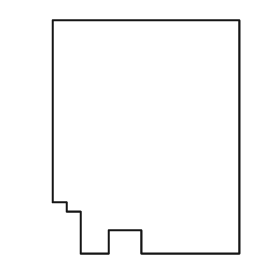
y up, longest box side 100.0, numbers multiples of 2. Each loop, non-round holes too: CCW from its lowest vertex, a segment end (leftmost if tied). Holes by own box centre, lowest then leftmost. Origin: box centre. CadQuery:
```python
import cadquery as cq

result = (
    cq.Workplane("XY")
    .moveTo(-28.0, -50.0)
    .lineTo(-16.0, -50.0)
    .lineTo(-16.0, -40.0)
    .lineTo(-2.0, -40.0)
    .lineTo(-2.0, -50.0)
    .lineTo(40.0, -50.0)
    .lineTo(40.0, 50.0)
    .lineTo(-40.0, 50.0)
    .lineTo(-40.0, -28.0)
    .lineTo(-34.0, -28.0)
    .lineTo(-34.0, -32.0)
    .lineTo(-28.0, -32.0)
    .close()
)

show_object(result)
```